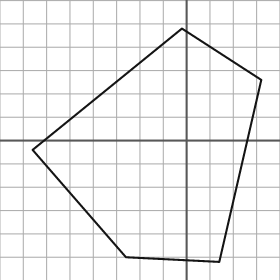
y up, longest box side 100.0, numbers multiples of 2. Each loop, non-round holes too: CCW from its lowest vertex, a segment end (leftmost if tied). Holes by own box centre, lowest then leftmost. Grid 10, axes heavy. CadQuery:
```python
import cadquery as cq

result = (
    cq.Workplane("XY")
    .moveTo(14.0, -52.0)
    .lineTo(32.0, 26.0)
    .lineTo(-2.0, 48.0)
    .lineTo(-66.0, -4.0)
    .lineTo(-26.0, -50.0)
    .close()
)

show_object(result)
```